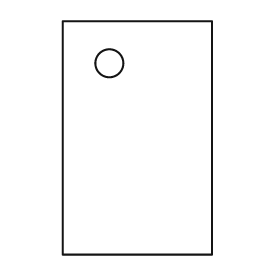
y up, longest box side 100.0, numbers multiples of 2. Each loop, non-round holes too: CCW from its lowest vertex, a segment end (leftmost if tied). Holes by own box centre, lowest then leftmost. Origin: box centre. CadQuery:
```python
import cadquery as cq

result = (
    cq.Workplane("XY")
    .moveTo(-32.0, -50.0)
    .lineTo(32.0, -50.0)
    .lineTo(32.0, 50.0)
    .lineTo(-32.0, 50.0)
    .close()
    .moveTo(-12.0, 32.0)
    .circle(6.0)
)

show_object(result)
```